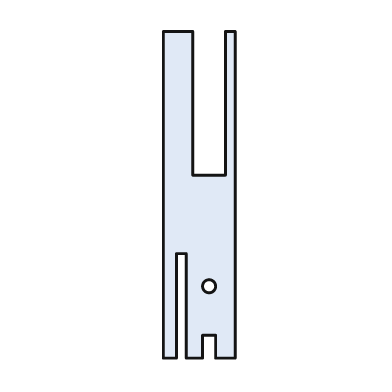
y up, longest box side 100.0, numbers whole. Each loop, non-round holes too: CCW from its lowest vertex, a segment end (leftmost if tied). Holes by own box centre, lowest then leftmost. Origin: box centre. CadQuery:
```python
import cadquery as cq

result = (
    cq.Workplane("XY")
    .moveTo(-11.0, -50.0)
    .lineTo(-7.0, -50.0)
    .lineTo(-7.0, -18.0)
    .lineTo(-4.0, -18.0)
    .lineTo(-4.0, -50.0)
    .lineTo(1.0, -50.0)
    .lineTo(1.0, -43.0)
    .lineTo(5.0, -43.0)
    .lineTo(5.0, -50.0)
    .lineTo(11.0, -50.0)
    .lineTo(11.0, 50.0)
    .lineTo(8.0, 50.0)
    .lineTo(8.0, 6.0)
    .lineTo(-2.0, 6.0)
    .lineTo(-2.0, 50.0)
    .lineTo(-11.0, 50.0)
    .close()
    .moveTo(3.0, -28.0)
    .circle(2.0)
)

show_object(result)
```